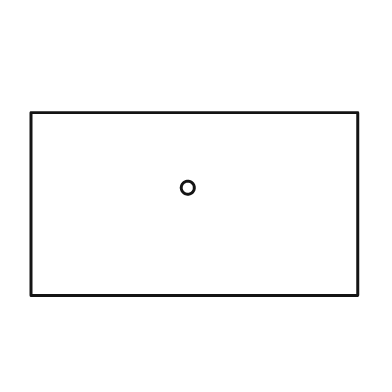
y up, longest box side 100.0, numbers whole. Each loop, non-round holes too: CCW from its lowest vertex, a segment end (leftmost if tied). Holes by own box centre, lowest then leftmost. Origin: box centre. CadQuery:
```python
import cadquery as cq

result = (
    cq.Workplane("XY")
    .moveTo(-50.0, -28.0)
    .lineTo(50.0, -28.0)
    .lineTo(50.0, 28.0)
    .lineTo(-50.0, 28.0)
    .close()
    .moveTo(-2.0, 5.0)
    .circle(2.0)
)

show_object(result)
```